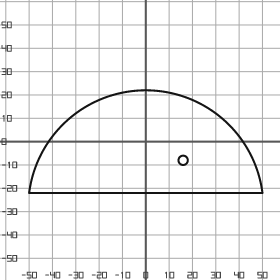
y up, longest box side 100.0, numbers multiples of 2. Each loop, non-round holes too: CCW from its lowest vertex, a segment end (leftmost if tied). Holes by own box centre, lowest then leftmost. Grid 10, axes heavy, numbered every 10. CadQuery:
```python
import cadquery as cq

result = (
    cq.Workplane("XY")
    .moveTo(-50.0, -22.0)
    .lineTo(50.0, -22.0)
    .threePointArc((0.0, 22.0), (-50.0, -22.0))
    .close()
    .moveTo(16.0, -8.0)
    .circle(2.0)
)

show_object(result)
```